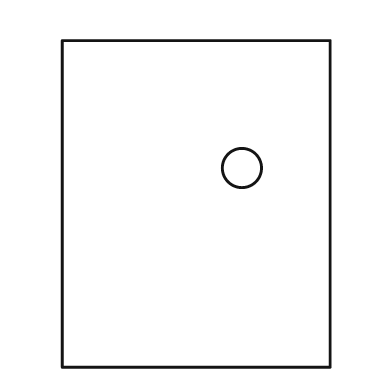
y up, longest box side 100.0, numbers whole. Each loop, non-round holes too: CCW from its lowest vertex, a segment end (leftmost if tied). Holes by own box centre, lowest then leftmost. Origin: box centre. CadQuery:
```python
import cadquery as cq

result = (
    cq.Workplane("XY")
    .moveTo(-41.0, -50.0)
    .lineTo(41.0, -50.0)
    .lineTo(41.0, 50.0)
    .lineTo(-41.0, 50.0)
    .close()
    .moveTo(14.0, 11.0)
    .circle(6.0)
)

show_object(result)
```